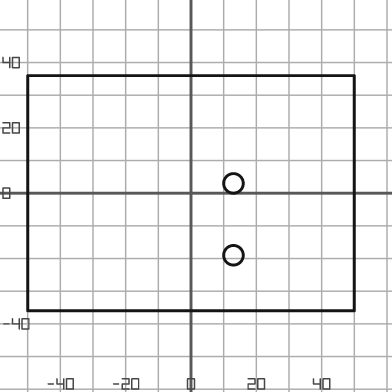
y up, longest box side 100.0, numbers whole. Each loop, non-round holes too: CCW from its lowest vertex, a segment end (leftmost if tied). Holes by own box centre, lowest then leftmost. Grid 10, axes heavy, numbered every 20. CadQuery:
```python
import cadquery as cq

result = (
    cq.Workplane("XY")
    .moveTo(-50.0, -36.0)
    .lineTo(50.0, -36.0)
    .lineTo(50.0, 36.0)
    .lineTo(-50.0, 36.0)
    .close()
    .moveTo(13.0, -19.0)
    .circle(3.0)
    .moveTo(13.0, 3.0)
    .circle(3.0)
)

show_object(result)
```